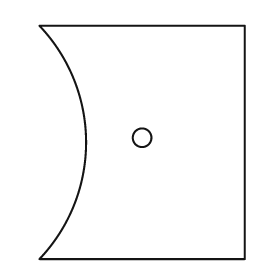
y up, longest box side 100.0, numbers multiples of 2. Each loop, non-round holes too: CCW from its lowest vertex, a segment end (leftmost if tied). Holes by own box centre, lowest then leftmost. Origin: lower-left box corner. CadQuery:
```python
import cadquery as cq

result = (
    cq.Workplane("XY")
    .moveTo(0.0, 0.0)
    .lineTo(88.0, 0.0)
    .lineTo(88.0, 100.0)
    .lineTo(0.0, 100.0)
    .threePointArc((20.0, 50.0), (0.0, 0.0))
    .close()
    .moveTo(44.0, 52.0)
    .circle(4.0)
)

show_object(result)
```